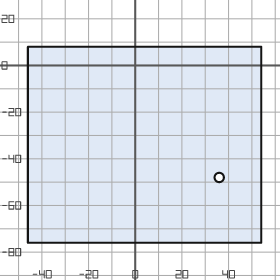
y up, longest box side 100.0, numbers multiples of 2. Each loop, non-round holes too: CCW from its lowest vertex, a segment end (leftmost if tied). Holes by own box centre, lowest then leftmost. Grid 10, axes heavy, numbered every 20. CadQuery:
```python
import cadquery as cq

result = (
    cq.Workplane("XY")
    .moveTo(-46.0, -76.0)
    .lineTo(54.0, -76.0)
    .lineTo(54.0, 8.0)
    .lineTo(-46.0, 8.0)
    .close()
    .moveTo(36.0, -48.0)
    .circle(2.0)
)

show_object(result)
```